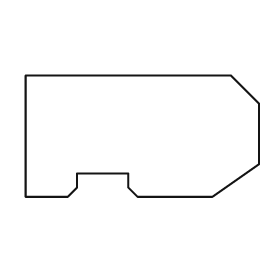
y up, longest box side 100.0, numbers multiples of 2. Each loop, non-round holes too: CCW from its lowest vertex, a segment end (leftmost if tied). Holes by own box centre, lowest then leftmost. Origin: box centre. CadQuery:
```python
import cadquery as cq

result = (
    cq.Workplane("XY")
    .moveTo(-50.0, -26.0)
    .lineTo(-32.0, -26.0)
    .lineTo(-28.0, -22.0)
    .lineTo(-28.0, -16.0)
    .lineTo(-6.0, -16.0)
    .lineTo(-6.0, -22.0)
    .lineTo(-2.0, -26.0)
    .lineTo(30.0, -26.0)
    .lineTo(50.0, -12.0)
    .lineTo(50.0, 14.0)
    .lineTo(38.0, 26.0)
    .lineTo(-50.0, 26.0)
    .close()
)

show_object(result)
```